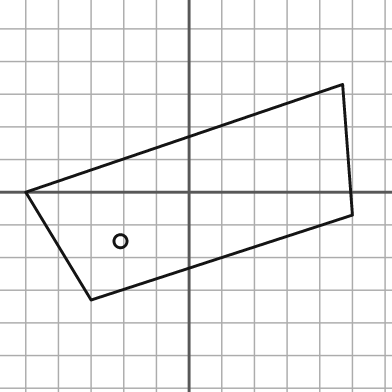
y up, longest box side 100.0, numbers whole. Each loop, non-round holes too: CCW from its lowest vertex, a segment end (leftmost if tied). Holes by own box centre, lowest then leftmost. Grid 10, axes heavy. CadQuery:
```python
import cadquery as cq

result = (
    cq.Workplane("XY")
    .moveTo(-30.0, -33.0)
    .lineTo(50.0, -7.0)
    .lineTo(47.0, 33.0)
    .lineTo(-50.0, 0.0)
    .close()
    .moveTo(-21.0, -15.0)
    .circle(2.0)
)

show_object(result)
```